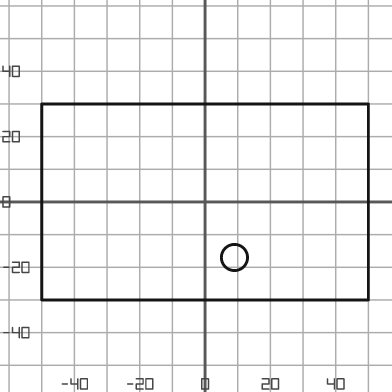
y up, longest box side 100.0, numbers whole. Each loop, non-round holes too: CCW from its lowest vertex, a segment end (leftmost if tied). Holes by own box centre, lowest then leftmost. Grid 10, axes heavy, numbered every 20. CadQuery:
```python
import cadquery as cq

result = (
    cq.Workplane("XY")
    .moveTo(-50.0, -30.0)
    .lineTo(50.0, -30.0)
    .lineTo(50.0, 30.0)
    .lineTo(-50.0, 30.0)
    .close()
    .moveTo(9.0, -17.0)
    .circle(4.0)
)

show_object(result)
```